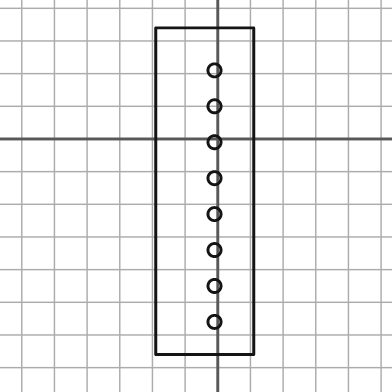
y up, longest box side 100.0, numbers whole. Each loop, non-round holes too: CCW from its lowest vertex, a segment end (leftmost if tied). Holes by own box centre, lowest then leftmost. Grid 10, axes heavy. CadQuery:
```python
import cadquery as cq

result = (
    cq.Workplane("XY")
    .moveTo(-19.0, -66.0)
    .lineTo(11.0, -66.0)
    .lineTo(11.0, 34.0)
    .lineTo(-19.0, 34.0)
    .close()
    .moveTo(-1.0, -56.0)
    .circle(2.0)
    .moveTo(-1.0, -45.0)
    .circle(2.0)
    .moveTo(-1.0, -34.0)
    .circle(2.0)
    .moveTo(-1.0, -23.0)
    .circle(2.0)
    .moveTo(-1.0, -12.0)
    .circle(2.0)
    .moveTo(-1.0, -1.0)
    .circle(2.0)
    .moveTo(-1.0, 10.0)
    .circle(2.0)
    .moveTo(-1.0, 21.0)
    .circle(2.0)
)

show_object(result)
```